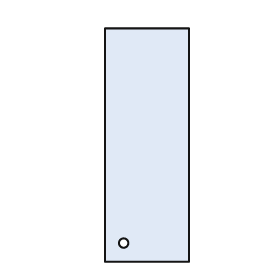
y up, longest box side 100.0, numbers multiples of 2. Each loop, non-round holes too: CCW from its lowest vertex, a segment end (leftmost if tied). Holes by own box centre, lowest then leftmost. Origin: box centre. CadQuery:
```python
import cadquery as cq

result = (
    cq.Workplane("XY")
    .moveTo(-18.0, -50.0)
    .lineTo(18.0, -50.0)
    .lineTo(18.0, 50.0)
    .lineTo(-18.0, 50.0)
    .close()
    .moveTo(-10.0, -42.0)
    .circle(2.0)
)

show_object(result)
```